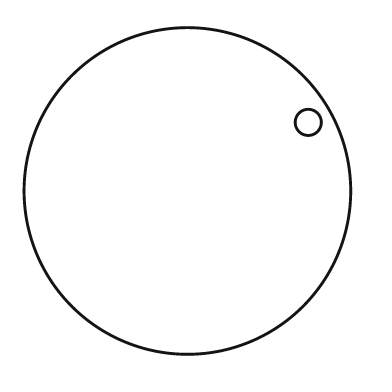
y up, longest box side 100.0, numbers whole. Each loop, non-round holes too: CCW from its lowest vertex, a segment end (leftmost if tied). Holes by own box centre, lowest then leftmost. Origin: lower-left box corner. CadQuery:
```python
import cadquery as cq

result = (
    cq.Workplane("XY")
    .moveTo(50.0, 50.0)
    .circle(50.0)
    .moveTo(87.0, 71.0)
    .circle(4.0)
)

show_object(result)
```